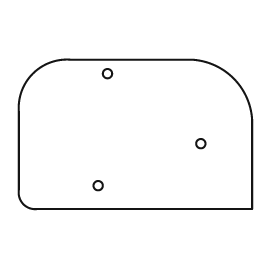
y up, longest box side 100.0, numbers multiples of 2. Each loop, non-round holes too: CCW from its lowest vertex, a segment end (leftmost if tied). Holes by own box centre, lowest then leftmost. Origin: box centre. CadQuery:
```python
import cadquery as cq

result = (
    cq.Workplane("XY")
    .moveTo(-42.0, -32.0)
    .lineTo(50.0, -32.0)
    .lineTo(50.0, 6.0)
    .threePointArc((42.0, 24.0), (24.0, 32.0))
    .lineTo(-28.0, 32.0)
    .threePointArc((-44.0, 26.0), (-50.0, 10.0))
    .lineTo(-50.0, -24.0)
    .threePointArc((-48.0, -30.0), (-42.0, -32.0))
    .close()
    .moveTo(-16.0, -22.0)
    .circle(2.0)
    .moveTo(28.0, -4.0)
    .circle(2.0)
    .moveTo(-12.0, 26.0)
    .circle(2.0)
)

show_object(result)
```